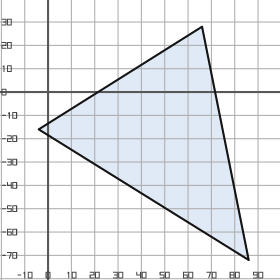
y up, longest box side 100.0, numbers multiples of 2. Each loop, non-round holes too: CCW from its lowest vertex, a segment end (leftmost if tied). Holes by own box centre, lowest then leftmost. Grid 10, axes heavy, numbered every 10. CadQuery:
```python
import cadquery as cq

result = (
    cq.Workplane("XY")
    .moveTo(86.0, -72.0)
    .lineTo(66.0, 28.0)
    .lineTo(-4.0, -16.0)
    .close()
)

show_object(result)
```